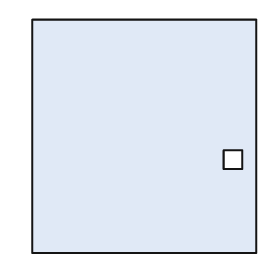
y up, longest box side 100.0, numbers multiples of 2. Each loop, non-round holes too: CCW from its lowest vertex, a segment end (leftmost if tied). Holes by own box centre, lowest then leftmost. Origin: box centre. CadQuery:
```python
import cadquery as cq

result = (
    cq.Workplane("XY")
    .moveTo(-48.0, -50.0)
    .lineTo(48.0, -50.0)
    .lineTo(48.0, 50.0)
    .lineTo(-48.0, 50.0)
    .close()
    .moveTo(34.0, -14.0)
    .lineTo(42.0, -14.0)
    .lineTo(42.0, -6.0)
    .lineTo(34.0, -6.0)
    .close()
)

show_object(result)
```